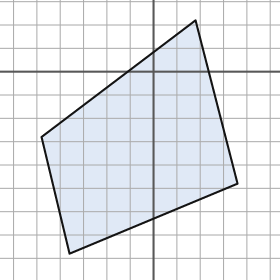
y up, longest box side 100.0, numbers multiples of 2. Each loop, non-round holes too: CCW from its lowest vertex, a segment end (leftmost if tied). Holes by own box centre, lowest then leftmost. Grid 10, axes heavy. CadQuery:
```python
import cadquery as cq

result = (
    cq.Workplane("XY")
    .moveTo(-36.0, -78.0)
    .lineTo(36.0, -48.0)
    .lineTo(18.0, 22.0)
    .lineTo(-48.0, -28.0)
    .close()
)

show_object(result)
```